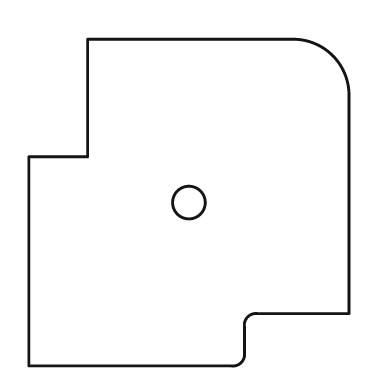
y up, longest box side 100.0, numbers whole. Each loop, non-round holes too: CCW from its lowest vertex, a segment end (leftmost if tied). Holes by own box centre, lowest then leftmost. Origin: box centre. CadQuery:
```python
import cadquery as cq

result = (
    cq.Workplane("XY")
    .moveTo(-49.0, -50.0)
    .lineTo(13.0, -50.0)
    .threePointArc((16.0, -49.0), (17.0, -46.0))
    .lineTo(17.0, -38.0)
    .threePointArc((18.0, -35.0), (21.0, -34.0))
    .lineTo(49.0, -34.0)
    .lineTo(49.0, 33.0)
    .threePointArc((44.0, 45.0), (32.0, 50.0))
    .lineTo(-31.0, 50.0)
    .lineTo(-31.0, 14.0)
    .lineTo(-49.0, 14.0)
    .close()
    .moveTo(0.0, 0.0)
    .circle(5.0)
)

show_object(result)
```